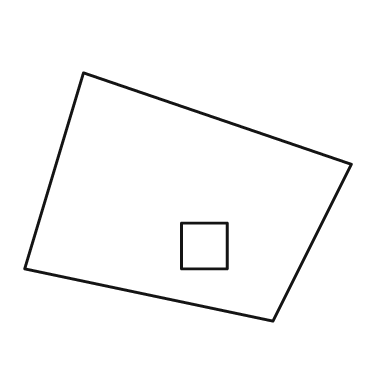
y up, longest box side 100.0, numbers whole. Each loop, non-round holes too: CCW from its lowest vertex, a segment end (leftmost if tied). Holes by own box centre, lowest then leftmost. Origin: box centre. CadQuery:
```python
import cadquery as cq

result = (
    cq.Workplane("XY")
    .moveTo(26.0, -38.0)
    .lineTo(50.0, 10.0)
    .lineTo(-32.0, 38.0)
    .lineTo(-50.0, -22.0)
    .close()
    .moveTo(-2.0, -22.0)
    .lineTo(12.0, -22.0)
    .lineTo(12.0, -8.0)
    .lineTo(-2.0, -8.0)
    .close()
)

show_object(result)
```